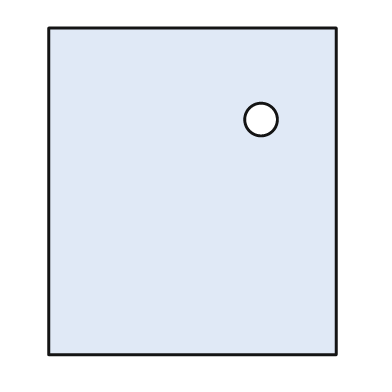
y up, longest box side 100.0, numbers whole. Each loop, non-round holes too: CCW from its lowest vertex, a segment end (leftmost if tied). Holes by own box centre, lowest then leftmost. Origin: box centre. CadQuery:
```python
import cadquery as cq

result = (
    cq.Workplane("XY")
    .moveTo(-44.0, -50.0)
    .lineTo(44.0, -50.0)
    .lineTo(44.0, 50.0)
    .lineTo(-44.0, 50.0)
    .close()
    .moveTo(21.0, 22.0)
    .circle(5.0)
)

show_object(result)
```